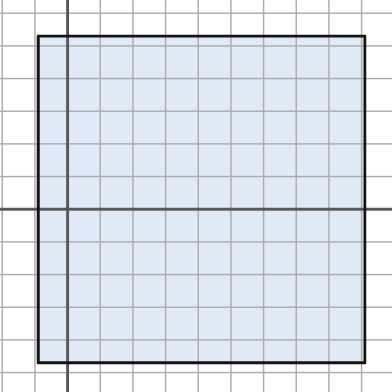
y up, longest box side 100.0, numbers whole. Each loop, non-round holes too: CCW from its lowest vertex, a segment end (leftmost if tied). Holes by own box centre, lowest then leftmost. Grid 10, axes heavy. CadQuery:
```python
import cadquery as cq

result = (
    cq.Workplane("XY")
    .moveTo(-9.0, -47.0)
    .lineTo(91.0, -47.0)
    .lineTo(91.0, 53.0)
    .lineTo(-9.0, 53.0)
    .close()
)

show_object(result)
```